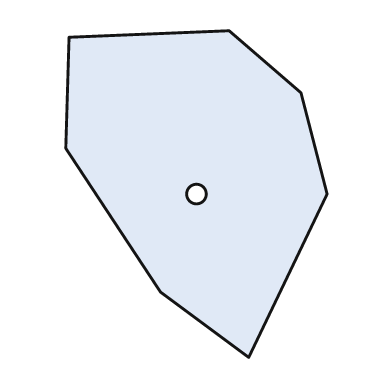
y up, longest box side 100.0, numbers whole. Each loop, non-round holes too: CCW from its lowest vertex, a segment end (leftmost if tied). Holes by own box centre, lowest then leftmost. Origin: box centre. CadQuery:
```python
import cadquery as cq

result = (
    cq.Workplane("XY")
    .moveTo(16.0, -50.0)
    .lineTo(40.0, 0.0)
    .lineTo(32.0, 31.0)
    .lineTo(10.0, 50.0)
    .lineTo(-39.0, 48.0)
    .lineTo(-40.0, 14.0)
    .lineTo(-11.0, -30.0)
    .close()
    .moveTo(0.0, 0.0)
    .circle(3.0)
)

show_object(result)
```